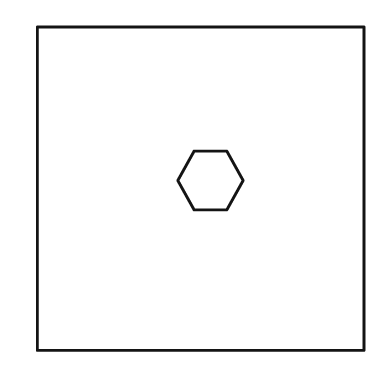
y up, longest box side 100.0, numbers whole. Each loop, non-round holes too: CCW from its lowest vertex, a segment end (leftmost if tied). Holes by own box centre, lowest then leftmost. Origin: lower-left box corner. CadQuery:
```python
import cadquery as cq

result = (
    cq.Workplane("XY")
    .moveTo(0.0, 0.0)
    .lineTo(100.0, 0.0)
    .lineTo(100.0, 99.0)
    .lineTo(0.0, 99.0)
    .close()
    .moveTo(48.0, 43.0)
    .lineTo(58.0, 43.0)
    .lineTo(63.0, 52.0)
    .lineTo(58.0, 61.0)
    .lineTo(48.0, 61.0)
    .lineTo(43.0, 52.0)
    .close()
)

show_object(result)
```